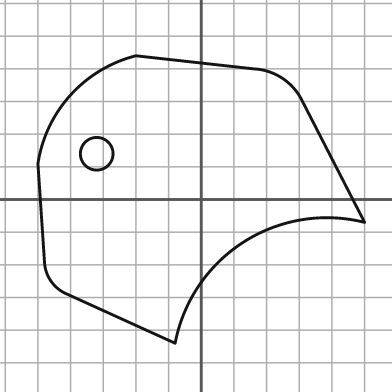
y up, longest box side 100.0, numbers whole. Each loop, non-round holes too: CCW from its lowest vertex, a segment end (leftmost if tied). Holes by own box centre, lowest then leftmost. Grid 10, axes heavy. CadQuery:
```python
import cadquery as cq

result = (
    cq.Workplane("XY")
    .moveTo(-8.0, -44.0)
    .threePointArc((13.0, -13.0), (50.0, -7.0))
    .lineTo(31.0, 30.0)
    .threePointArc((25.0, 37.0), (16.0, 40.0))
    .lineTo(-20.0, 44.0)
    .threePointArc((-40.0, 32.0), (-50.0, 11.0))
    .lineTo(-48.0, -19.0)
    .threePointArc((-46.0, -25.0), (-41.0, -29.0))
    .close()
    .moveTo(-32.0, 14.0)
    .circle(5.0)
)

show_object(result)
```